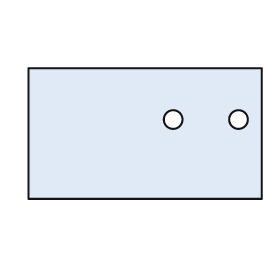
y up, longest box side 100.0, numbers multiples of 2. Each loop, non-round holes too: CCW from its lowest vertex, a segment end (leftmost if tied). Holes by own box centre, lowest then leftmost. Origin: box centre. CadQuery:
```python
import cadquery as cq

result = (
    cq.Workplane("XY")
    .moveTo(-50.0, -28.0)
    .lineTo(50.0, -28.0)
    .lineTo(50.0, 28.0)
    .lineTo(-50.0, 28.0)
    .close()
    .moveTo(12.0, 6.0)
    .circle(4.0)
    .moveTo(40.0, 6.0)
    .circle(4.0)
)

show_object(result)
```